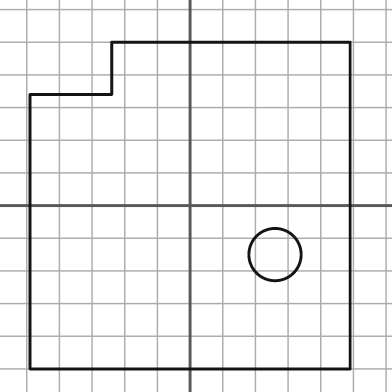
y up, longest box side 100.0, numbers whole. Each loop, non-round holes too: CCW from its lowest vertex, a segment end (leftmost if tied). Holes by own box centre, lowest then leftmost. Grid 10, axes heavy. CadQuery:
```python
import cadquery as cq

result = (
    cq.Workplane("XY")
    .moveTo(-49.0, -50.0)
    .lineTo(49.0, -50.0)
    .lineTo(49.0, 50.0)
    .lineTo(-24.0, 50.0)
    .lineTo(-24.0, 34.0)
    .lineTo(-49.0, 34.0)
    .close()
    .moveTo(26.0, -15.0)
    .circle(8.0)
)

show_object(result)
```